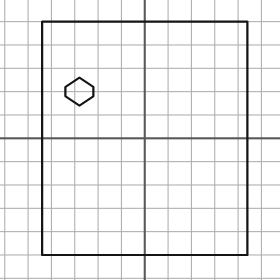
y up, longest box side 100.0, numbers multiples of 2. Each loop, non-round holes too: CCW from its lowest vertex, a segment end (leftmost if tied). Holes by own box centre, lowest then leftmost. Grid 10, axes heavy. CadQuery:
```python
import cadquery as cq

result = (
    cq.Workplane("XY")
    .moveTo(-44.0, -50.0)
    .lineTo(44.0, -50.0)
    .lineTo(44.0, 50.0)
    .lineTo(-44.0, 50.0)
    .close()
    .moveTo(-28.0, 14.0)
    .lineTo(-22.0, 18.0)
    .lineTo(-22.0, 22.0)
    .lineTo(-28.0, 26.0)
    .lineTo(-34.0, 22.0)
    .lineTo(-34.0, 18.0)
    .close()
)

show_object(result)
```